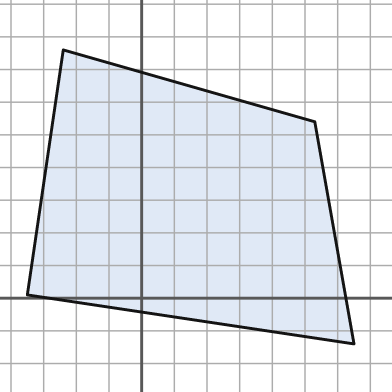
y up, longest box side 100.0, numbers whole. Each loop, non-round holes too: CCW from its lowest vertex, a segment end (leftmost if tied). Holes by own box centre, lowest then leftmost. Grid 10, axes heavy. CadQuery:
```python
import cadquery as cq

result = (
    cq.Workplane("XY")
    .moveTo(65.0, -14.0)
    .lineTo(53.0, 54.0)
    .lineTo(-24.0, 76.0)
    .lineTo(-35.0, 1.0)
    .close()
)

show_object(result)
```